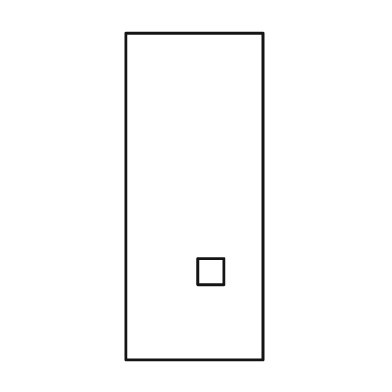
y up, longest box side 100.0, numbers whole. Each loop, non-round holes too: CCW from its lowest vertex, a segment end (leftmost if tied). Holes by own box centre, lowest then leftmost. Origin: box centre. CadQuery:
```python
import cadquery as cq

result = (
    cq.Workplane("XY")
    .moveTo(-21.0, -50.0)
    .lineTo(21.0, -50.0)
    .lineTo(21.0, 50.0)
    .lineTo(-21.0, 50.0)
    .close()
    .moveTo(1.0, -27.0)
    .lineTo(9.0, -27.0)
    .lineTo(9.0, -19.0)
    .lineTo(1.0, -19.0)
    .close()
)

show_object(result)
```